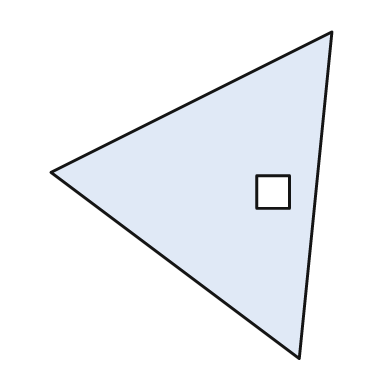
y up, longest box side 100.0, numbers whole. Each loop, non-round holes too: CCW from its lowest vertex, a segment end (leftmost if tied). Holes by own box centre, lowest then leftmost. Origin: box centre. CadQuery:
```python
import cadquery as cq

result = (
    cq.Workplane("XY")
    .moveTo(33.0, -50.0)
    .lineTo(43.0, 50.0)
    .lineTo(-43.0, 7.0)
    .close()
    .moveTo(20.0, -4.0)
    .lineTo(30.0, -4.0)
    .lineTo(30.0, 6.0)
    .lineTo(20.0, 6.0)
    .close()
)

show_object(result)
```